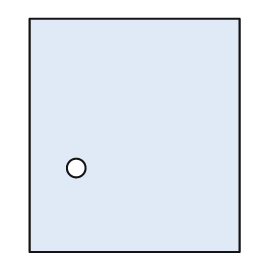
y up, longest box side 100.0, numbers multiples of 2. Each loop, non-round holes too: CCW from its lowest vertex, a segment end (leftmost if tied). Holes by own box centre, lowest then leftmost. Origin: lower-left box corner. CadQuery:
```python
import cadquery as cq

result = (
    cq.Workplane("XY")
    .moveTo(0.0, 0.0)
    .lineTo(90.0, 0.0)
    .lineTo(90.0, 100.0)
    .lineTo(0.0, 100.0)
    .close()
    .moveTo(20.0, 36.0)
    .circle(4.0)
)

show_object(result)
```